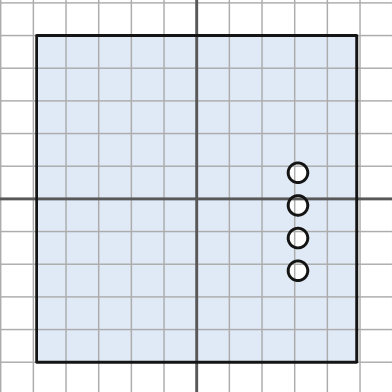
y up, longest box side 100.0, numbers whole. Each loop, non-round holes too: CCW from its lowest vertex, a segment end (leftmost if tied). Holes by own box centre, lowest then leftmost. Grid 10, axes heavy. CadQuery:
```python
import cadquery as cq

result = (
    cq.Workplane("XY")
    .moveTo(-49.0, -50.0)
    .lineTo(49.0, -50.0)
    .lineTo(49.0, 50.0)
    .lineTo(-49.0, 50.0)
    .close()
    .moveTo(31.0, -22.0)
    .circle(3.0)
    .moveTo(31.0, -12.0)
    .circle(3.0)
    .moveTo(31.0, -2.0)
    .circle(3.0)
    .moveTo(31.0, 8.0)
    .circle(3.0)
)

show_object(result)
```